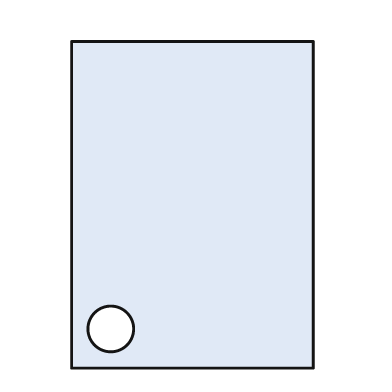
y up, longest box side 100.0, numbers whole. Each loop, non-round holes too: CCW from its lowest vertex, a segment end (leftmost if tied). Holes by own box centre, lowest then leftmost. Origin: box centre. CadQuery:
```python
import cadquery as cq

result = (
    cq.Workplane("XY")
    .moveTo(-37.0, -50.0)
    .lineTo(37.0, -50.0)
    .lineTo(37.0, 50.0)
    .lineTo(-37.0, 50.0)
    .close()
    .moveTo(-25.0, -38.0)
    .circle(7.0)
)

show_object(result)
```